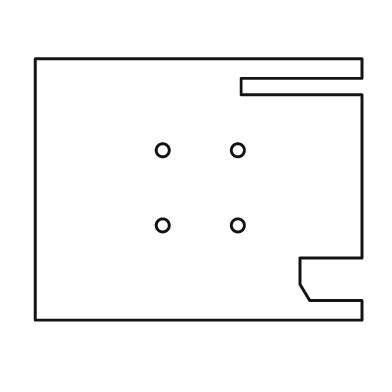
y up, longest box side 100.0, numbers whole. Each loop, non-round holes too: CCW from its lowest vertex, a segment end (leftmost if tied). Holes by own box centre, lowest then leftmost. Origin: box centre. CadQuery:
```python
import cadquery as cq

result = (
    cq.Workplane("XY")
    .moveTo(-50.0, -40.0)
    .lineTo(50.0, -40.0)
    .lineTo(50.0, -34.0)
    .lineTo(34.0, -34.0)
    .lineTo(31.0, -29.0)
    .lineTo(31.0, -21.0)
    .lineTo(50.0, -21.0)
    .lineTo(50.0, 29.0)
    .lineTo(13.0, 29.0)
    .lineTo(13.0, 34.0)
    .lineTo(50.0, 34.0)
    .lineTo(50.0, 40.0)
    .lineTo(-50.0, 40.0)
    .close()
    .moveTo(-11.0, -11.0)
    .circle(2.0)
    .moveTo(12.0, -11.0)
    .circle(2.0)
    .moveTo(-11.0, 12.0)
    .circle(2.0)
    .moveTo(12.0, 12.0)
    .circle(2.0)
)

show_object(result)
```